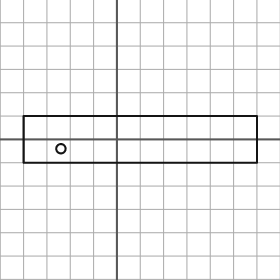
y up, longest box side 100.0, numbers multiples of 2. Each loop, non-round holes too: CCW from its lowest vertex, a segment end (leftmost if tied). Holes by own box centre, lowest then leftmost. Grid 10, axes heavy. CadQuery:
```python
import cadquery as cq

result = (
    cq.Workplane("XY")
    .moveTo(-40.0, -10.0)
    .lineTo(60.0, -10.0)
    .lineTo(60.0, 10.0)
    .lineTo(-40.0, 10.0)
    .close()
    .moveTo(-24.0, -4.0)
    .circle(2.0)
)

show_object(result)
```